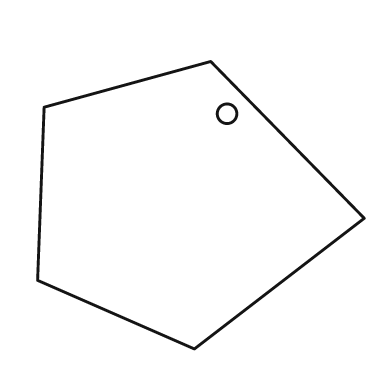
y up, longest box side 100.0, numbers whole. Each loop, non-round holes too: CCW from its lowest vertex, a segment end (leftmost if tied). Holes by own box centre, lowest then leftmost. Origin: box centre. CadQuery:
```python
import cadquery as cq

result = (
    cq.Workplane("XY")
    .moveTo(-2.0, -44.0)
    .lineTo(50.0, -4.0)
    .lineTo(3.0, 44.0)
    .lineTo(-48.0, 30.0)
    .lineTo(-50.0, -23.0)
    .close()
    .moveTo(8.0, 28.0)
    .circle(3.0)
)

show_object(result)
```